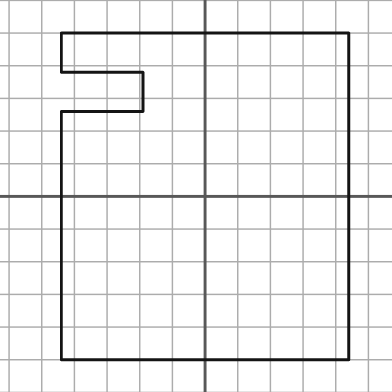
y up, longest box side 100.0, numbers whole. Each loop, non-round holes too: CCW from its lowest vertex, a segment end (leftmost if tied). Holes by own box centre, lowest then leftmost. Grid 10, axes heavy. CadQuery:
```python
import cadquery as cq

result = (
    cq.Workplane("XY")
    .moveTo(-44.0, -50.0)
    .lineTo(44.0, -50.0)
    .lineTo(44.0, 50.0)
    .lineTo(-44.0, 50.0)
    .lineTo(-44.0, 38.0)
    .lineTo(-19.0, 38.0)
    .lineTo(-19.0, 26.0)
    .lineTo(-44.0, 26.0)
    .close()
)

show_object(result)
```